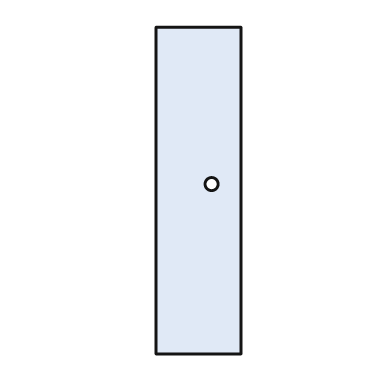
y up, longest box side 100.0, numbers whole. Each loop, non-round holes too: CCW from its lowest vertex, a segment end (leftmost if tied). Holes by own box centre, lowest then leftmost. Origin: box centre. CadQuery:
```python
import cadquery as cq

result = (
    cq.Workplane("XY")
    .moveTo(-13.0, -50.0)
    .lineTo(13.0, -50.0)
    .lineTo(13.0, 50.0)
    .lineTo(-13.0, 50.0)
    .close()
    .moveTo(4.0, 2.0)
    .circle(2.0)
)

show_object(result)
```